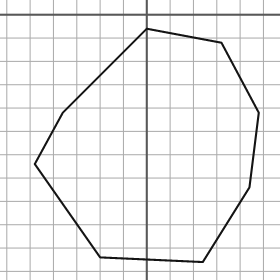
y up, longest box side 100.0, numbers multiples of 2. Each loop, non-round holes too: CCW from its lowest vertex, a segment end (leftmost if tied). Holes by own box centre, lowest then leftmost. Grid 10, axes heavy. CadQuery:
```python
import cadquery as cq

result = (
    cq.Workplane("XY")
    .moveTo(24.0, -106.0)
    .lineTo(44.0, -74.0)
    .lineTo(48.0, -42.0)
    .lineTo(32.0, -12.0)
    .lineTo(0.0, -6.0)
    .lineTo(-36.0, -42.0)
    .lineTo(-48.0, -64.0)
    .lineTo(-20.0, -104.0)
    .close()
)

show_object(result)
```